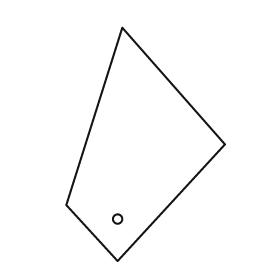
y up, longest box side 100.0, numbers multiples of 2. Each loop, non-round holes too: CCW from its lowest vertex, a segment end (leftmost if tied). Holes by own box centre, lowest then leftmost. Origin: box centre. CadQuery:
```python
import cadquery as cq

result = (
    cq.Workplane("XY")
    .moveTo(-12.0, -50.0)
    .lineTo(34.0, 0.0)
    .lineTo(-10.0, 50.0)
    .lineTo(-34.0, -26.0)
    .close()
    .moveTo(-12.0, -32.0)
    .circle(2.0)
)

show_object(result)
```